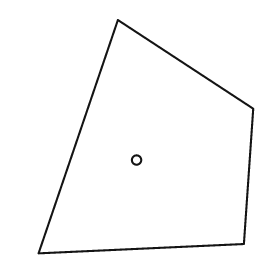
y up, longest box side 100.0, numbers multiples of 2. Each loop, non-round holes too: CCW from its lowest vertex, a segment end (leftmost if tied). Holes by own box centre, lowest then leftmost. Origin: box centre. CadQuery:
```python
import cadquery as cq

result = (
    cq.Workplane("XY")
    .moveTo(-46.0, -50.0)
    .lineTo(42.0, -46.0)
    .lineTo(46.0, 12.0)
    .lineTo(-12.0, 50.0)
    .close()
    .moveTo(-4.0, -10.0)
    .circle(2.0)
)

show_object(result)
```